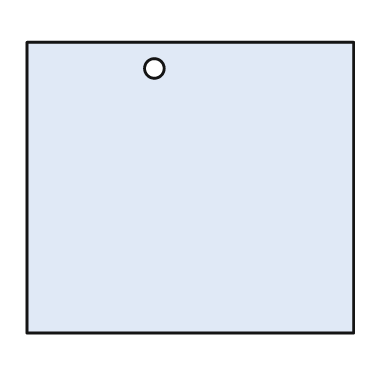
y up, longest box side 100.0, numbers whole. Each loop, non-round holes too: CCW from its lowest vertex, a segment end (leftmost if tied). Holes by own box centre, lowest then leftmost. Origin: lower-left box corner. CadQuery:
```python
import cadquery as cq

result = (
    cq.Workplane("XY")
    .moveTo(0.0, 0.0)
    .lineTo(100.0, 0.0)
    .lineTo(100.0, 89.0)
    .lineTo(0.0, 89.0)
    .close()
    .moveTo(39.0, 81.0)
    .circle(3.0)
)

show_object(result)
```